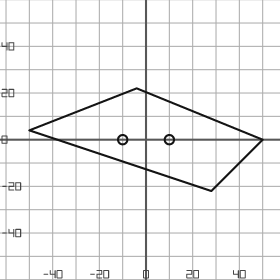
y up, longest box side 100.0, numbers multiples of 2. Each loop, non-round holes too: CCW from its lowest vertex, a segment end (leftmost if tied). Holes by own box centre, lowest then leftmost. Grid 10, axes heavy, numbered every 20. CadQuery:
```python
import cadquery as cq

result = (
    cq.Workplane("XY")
    .moveTo(28.0, -22.0)
    .lineTo(50.0, 0.0)
    .lineTo(-4.0, 22.0)
    .lineTo(-50.0, 4.0)
    .close()
    .moveTo(-10.0, 0.0)
    .circle(2.0)
    .moveTo(10.0, 0.0)
    .circle(2.0)
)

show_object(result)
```